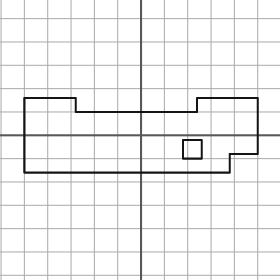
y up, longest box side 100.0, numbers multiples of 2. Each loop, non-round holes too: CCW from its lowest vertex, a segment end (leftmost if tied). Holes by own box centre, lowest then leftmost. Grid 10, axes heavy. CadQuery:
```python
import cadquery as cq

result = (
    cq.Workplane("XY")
    .moveTo(-50.0, -16.0)
    .lineTo(38.0, -16.0)
    .lineTo(38.0, -8.0)
    .lineTo(50.0, -8.0)
    .lineTo(50.0, 16.0)
    .lineTo(24.0, 16.0)
    .lineTo(24.0, 10.0)
    .lineTo(-28.0, 10.0)
    .lineTo(-28.0, 16.0)
    .lineTo(-50.0, 16.0)
    .close()
    .moveTo(18.0, -10.0)
    .lineTo(26.0, -10.0)
    .lineTo(26.0, -2.0)
    .lineTo(18.0, -2.0)
    .close()
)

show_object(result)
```